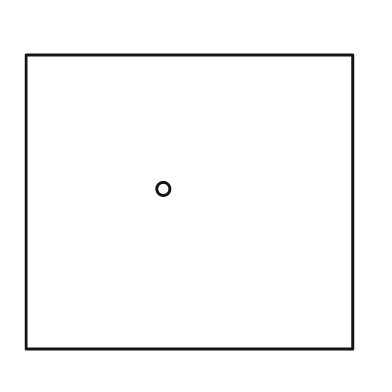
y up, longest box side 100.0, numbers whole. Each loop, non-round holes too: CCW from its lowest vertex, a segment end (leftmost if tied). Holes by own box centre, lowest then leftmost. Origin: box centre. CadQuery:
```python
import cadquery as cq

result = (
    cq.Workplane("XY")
    .moveTo(-50.0, -45.0)
    .lineTo(50.0, -45.0)
    .lineTo(50.0, 45.0)
    .lineTo(-50.0, 45.0)
    .close()
    .moveTo(-8.0, 4.0)
    .circle(2.0)
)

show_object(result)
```